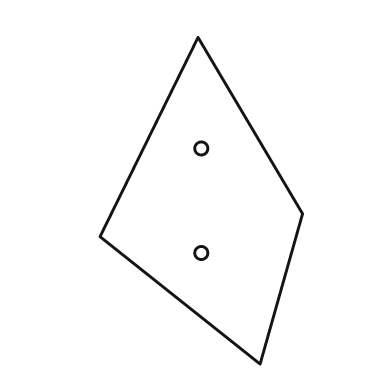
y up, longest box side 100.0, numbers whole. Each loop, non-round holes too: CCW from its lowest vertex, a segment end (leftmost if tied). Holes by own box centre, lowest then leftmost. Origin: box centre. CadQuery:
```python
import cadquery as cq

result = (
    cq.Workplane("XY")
    .moveTo(18.0, -50.0)
    .lineTo(31.0, -4.0)
    .lineTo(-1.0, 50.0)
    .lineTo(-31.0, -11.0)
    .close()
    .moveTo(0.0, -16.0)
    .circle(2.0)
    .moveTo(0.0, 16.0)
    .circle(2.0)
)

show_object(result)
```